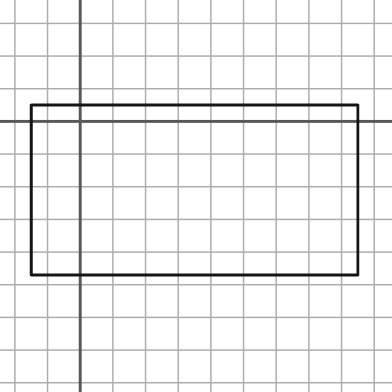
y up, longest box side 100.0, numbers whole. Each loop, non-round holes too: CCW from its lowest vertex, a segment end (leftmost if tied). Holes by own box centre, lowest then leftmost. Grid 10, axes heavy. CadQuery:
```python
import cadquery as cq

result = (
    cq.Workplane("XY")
    .moveTo(-15.0, -47.0)
    .lineTo(85.0, -47.0)
    .lineTo(85.0, 5.0)
    .lineTo(-15.0, 5.0)
    .close()
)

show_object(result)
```